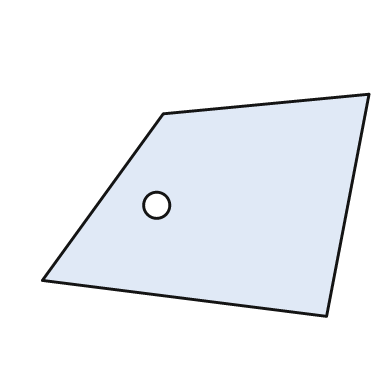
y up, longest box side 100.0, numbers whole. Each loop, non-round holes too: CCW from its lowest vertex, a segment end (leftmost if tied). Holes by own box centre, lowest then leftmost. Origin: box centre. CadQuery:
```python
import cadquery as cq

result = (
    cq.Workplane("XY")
    .moveTo(37.0, -34.0)
    .lineTo(50.0, 34.0)
    .lineTo(-13.0, 28.0)
    .lineTo(-50.0, -23.0)
    .close()
    .moveTo(-15.0, 0.0)
    .circle(4.0)
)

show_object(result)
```